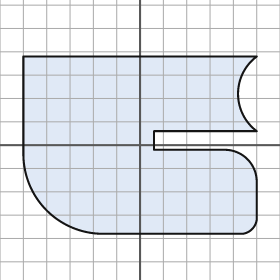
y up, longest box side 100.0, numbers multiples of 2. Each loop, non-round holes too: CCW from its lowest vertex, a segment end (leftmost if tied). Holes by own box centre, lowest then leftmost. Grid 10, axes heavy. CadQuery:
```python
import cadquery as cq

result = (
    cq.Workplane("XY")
    .moveTo(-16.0, -38.0)
    .lineTo(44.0, -38.0)
    .threePointArc((48.0, -36.0), (50.0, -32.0))
    .lineTo(50.0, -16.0)
    .threePointArc((46.0, -6.0), (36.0, -2.0))
    .lineTo(6.0, -2.0)
    .lineTo(6.0, 6.0)
    .lineTo(50.0, 6.0)
    .threePointArc((42.0, 22.0), (50.0, 38.0))
    .lineTo(-50.0, 38.0)
    .lineTo(-50.0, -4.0)
    .threePointArc((-40.0, -28.0), (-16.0, -38.0))
    .close()
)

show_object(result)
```